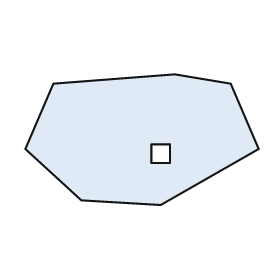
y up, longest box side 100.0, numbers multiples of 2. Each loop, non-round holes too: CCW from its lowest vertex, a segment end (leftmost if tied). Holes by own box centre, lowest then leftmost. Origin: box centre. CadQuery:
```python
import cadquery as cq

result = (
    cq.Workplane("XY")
    .moveTo(8.0, -28.0)
    .lineTo(50.0, -4.0)
    .lineTo(38.0, 24.0)
    .lineTo(14.0, 28.0)
    .lineTo(-38.0, 24.0)
    .lineTo(-50.0, -4.0)
    .lineTo(-26.0, -26.0)
    .close()
    .moveTo(4.0, -10.0)
    .lineTo(12.0, -10.0)
    .lineTo(12.0, -2.0)
    .lineTo(4.0, -2.0)
    .close()
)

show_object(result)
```